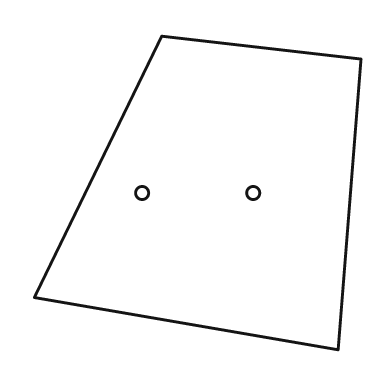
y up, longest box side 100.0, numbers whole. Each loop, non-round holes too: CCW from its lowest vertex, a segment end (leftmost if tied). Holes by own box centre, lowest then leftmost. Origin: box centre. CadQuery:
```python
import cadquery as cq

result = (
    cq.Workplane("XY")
    .moveTo(43.0, -48.0)
    .lineTo(50.0, 41.0)
    .lineTo(-11.0, 48.0)
    .lineTo(-50.0, -32.0)
    .close()
    .moveTo(-17.0, 0.0)
    .circle(2.0)
    .moveTo(17.0, 0.0)
    .circle(2.0)
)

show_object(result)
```